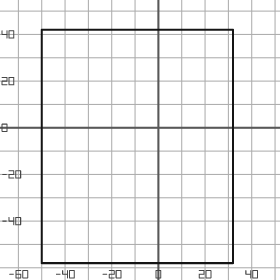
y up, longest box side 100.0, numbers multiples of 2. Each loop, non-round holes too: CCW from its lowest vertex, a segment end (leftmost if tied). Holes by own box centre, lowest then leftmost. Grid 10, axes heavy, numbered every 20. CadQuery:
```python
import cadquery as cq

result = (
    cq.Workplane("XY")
    .moveTo(-50.0, -58.0)
    .lineTo(32.0, -58.0)
    .lineTo(32.0, 42.0)
    .lineTo(-50.0, 42.0)
    .close()
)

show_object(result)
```